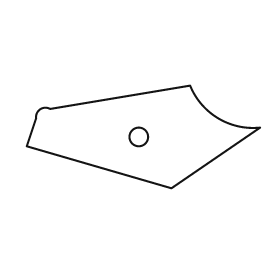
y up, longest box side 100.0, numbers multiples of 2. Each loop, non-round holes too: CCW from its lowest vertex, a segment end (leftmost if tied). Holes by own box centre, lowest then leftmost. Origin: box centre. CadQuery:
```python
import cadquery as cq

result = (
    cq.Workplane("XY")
    .moveTo(12.0, -22.0)
    .lineTo(50.0, 4.0)
    .threePointArc((32.0, 8.0), (20.0, 22.0))
    .lineTo(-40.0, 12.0)
    .threePointArc((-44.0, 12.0), (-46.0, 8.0))
    .lineTo(-50.0, -4.0)
    .close()
    .moveTo(-2.0, 0.0)
    .circle(4.0)
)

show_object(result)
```